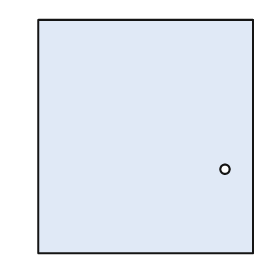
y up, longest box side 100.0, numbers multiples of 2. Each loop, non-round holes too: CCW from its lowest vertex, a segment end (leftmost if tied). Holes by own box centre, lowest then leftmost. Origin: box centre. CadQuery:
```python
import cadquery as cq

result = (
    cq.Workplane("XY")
    .moveTo(-46.0, -50.0)
    .lineTo(46.0, -50.0)
    .lineTo(46.0, 50.0)
    .lineTo(-46.0, 50.0)
    .close()
    .moveTo(34.0, -14.0)
    .circle(2.0)
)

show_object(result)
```